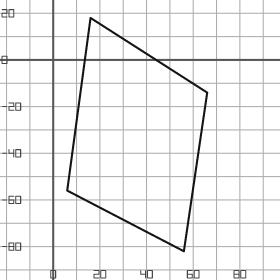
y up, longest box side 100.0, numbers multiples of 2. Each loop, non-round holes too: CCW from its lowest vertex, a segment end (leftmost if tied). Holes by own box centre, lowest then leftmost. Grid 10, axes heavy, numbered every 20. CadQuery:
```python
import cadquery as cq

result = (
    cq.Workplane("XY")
    .moveTo(56.0, -82.0)
    .lineTo(66.0, -14.0)
    .lineTo(16.0, 18.0)
    .lineTo(6.0, -56.0)
    .close()
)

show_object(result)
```